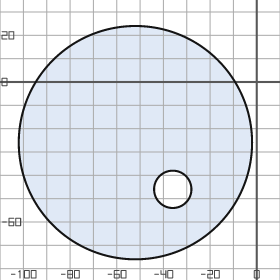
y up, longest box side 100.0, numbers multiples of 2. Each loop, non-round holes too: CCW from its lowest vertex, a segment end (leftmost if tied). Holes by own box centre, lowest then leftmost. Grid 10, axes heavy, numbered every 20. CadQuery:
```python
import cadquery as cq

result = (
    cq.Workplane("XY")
    .moveTo(-52.0, -26.0)
    .circle(50.0)
    .moveTo(-36.0, -46.0)
    .circle(8.0)
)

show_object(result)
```